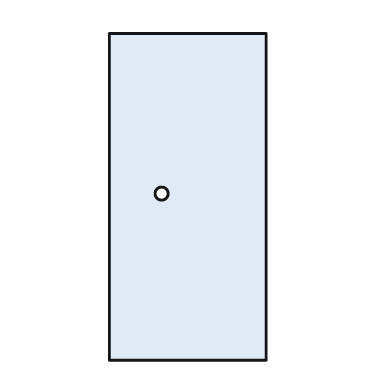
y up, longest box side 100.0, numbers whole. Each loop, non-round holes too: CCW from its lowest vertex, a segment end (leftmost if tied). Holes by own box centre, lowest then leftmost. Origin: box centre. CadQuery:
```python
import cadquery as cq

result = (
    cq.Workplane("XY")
    .moveTo(-24.0, -50.0)
    .lineTo(24.0, -50.0)
    .lineTo(24.0, 50.0)
    .lineTo(-24.0, 50.0)
    .close()
    .moveTo(-8.0, 1.0)
    .circle(2.0)
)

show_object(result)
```